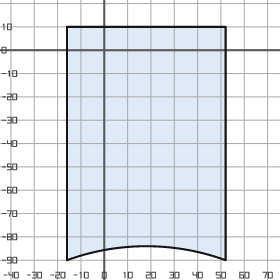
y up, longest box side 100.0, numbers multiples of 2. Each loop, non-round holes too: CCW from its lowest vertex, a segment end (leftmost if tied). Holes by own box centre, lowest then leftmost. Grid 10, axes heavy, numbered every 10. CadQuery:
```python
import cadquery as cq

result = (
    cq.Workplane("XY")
    .moveTo(-16.0, -90.0)
    .threePointArc((18.0, -84.0), (52.0, -90.0))
    .lineTo(52.0, 10.0)
    .lineTo(-16.0, 10.0)
    .close()
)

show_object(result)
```